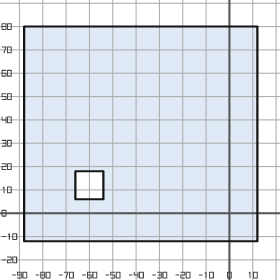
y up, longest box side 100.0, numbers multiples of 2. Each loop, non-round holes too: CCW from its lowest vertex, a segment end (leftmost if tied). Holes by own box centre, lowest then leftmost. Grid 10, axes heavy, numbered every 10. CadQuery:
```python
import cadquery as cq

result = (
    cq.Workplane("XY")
    .moveTo(-88.0, -12.0)
    .lineTo(12.0, -12.0)
    .lineTo(12.0, 80.0)
    .lineTo(-88.0, 80.0)
    .close()
    .moveTo(-66.0, 6.0)
    .lineTo(-54.0, 6.0)
    .lineTo(-54.0, 18.0)
    .lineTo(-66.0, 18.0)
    .close()
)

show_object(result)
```